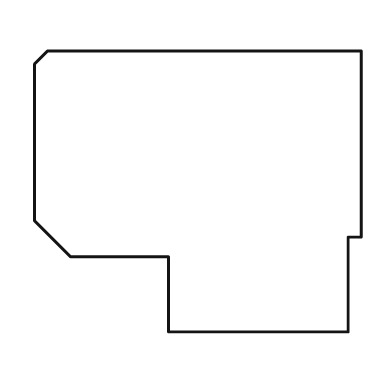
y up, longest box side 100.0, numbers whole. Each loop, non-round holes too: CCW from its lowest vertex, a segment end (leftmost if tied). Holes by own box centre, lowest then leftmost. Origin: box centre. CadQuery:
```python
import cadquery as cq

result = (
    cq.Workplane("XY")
    .moveTo(-9.0, -43.0)
    .lineTo(46.0, -43.0)
    .lineTo(46.0, -14.0)
    .lineTo(50.0, -14.0)
    .lineTo(50.0, 43.0)
    .lineTo(-46.0, 43.0)
    .lineTo(-50.0, 39.0)
    .lineTo(-50.0, -9.0)
    .lineTo(-39.0, -20.0)
    .lineTo(-9.0, -20.0)
    .close()
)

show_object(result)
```